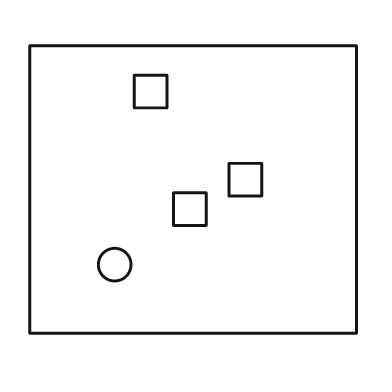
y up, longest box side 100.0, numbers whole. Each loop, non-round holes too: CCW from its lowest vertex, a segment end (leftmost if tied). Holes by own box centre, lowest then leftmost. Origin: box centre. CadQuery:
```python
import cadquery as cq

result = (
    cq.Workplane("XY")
    .moveTo(-50.0, -44.0)
    .lineTo(50.0, -44.0)
    .lineTo(50.0, 44.0)
    .lineTo(-50.0, 44.0)
    .close()
    .moveTo(-24.0, -23.0)
    .circle(5.0)
    .moveTo(-6.0, -11.0)
    .lineTo(4.0, -11.0)
    .lineTo(4.0, -1.0)
    .lineTo(-6.0, -1.0)
    .close()
    .moveTo(11.0, -2.0)
    .lineTo(21.0, -2.0)
    .lineTo(21.0, 8.0)
    .lineTo(11.0, 8.0)
    .close()
    .moveTo(-18.0, 25.0)
    .lineTo(-8.0, 25.0)
    .lineTo(-8.0, 35.0)
    .lineTo(-18.0, 35.0)
    .close()
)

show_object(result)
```